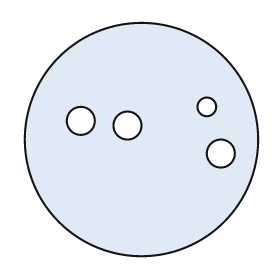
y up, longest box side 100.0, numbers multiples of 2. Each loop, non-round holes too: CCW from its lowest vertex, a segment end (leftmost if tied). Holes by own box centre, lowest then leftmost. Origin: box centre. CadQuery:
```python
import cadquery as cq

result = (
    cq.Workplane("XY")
    .moveTo(0.0, 0.0)
    .circle(50.0)
    .moveTo(34.0, -6.0)
    .circle(6.0)
    .moveTo(-6.0, 6.0)
    .circle(6.0)
    .moveTo(-26.0, 8.0)
    .circle(6.0)
    .moveTo(28.0, 14.0)
    .circle(4.0)
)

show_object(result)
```